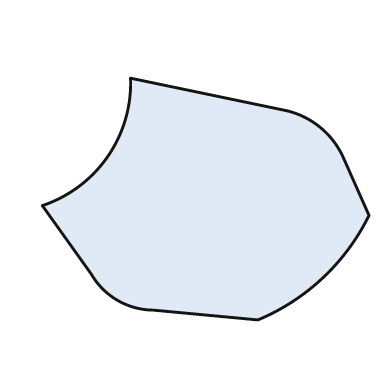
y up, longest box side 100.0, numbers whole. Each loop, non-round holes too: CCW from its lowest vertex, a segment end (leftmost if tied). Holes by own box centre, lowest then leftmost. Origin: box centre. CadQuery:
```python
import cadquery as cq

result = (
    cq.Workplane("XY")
    .moveTo(16.0, -37.0)
    .threePointArc((36.0, -24.0), (50.0, -5.0))
    .lineTo(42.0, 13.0)
    .threePointArc((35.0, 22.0), (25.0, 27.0))
    .lineTo(-23.0, 37.0)
    .threePointArc((-30.0, 13.0), (-50.0, -2.0))
    .lineTo(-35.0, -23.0)
    .threePointArc((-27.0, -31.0), (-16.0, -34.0))
    .close()
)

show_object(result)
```